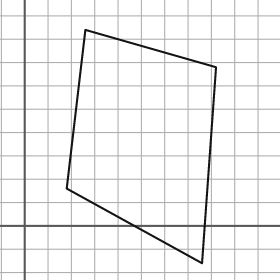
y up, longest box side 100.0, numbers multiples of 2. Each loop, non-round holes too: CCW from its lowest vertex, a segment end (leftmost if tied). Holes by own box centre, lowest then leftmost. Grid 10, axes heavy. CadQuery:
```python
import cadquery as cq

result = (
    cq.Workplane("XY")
    .moveTo(76.0, -16.0)
    .lineTo(82.0, 68.0)
    .lineTo(26.0, 84.0)
    .lineTo(18.0, 16.0)
    .close()
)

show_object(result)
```